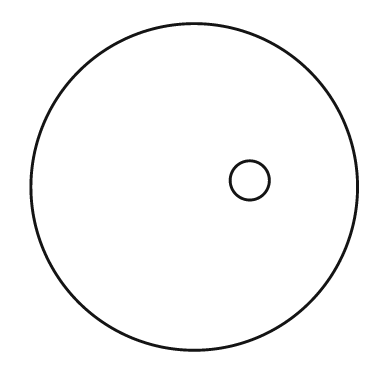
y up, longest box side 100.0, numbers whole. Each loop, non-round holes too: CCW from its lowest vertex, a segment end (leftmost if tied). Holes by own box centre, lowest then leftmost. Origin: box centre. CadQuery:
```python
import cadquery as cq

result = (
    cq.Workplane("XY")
    .moveTo(0.0, 0.0)
    .circle(50.0)
    .moveTo(17.0, 2.0)
    .circle(6.0)
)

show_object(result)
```